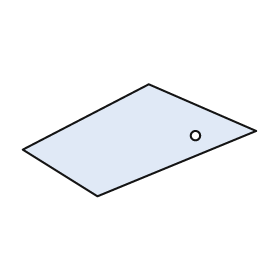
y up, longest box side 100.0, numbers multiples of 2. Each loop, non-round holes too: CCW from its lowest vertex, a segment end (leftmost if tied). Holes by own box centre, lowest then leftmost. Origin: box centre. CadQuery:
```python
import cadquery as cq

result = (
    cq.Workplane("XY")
    .moveTo(-18.0, -24.0)
    .lineTo(50.0, 4.0)
    .lineTo(4.0, 24.0)
    .lineTo(-50.0, -4.0)
    .close()
    .moveTo(24.0, 2.0)
    .circle(2.0)
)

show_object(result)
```